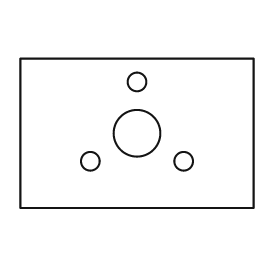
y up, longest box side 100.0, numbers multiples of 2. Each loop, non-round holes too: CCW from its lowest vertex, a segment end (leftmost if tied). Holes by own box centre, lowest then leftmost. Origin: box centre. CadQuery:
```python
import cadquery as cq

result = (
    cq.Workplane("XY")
    .moveTo(-50.0, -32.0)
    .lineTo(50.0, -32.0)
    .lineTo(50.0, 32.0)
    .lineTo(-50.0, 32.0)
    .close()
    .moveTo(-20.0, -12.0)
    .circle(4.0)
    .moveTo(20.0, -12.0)
    .circle(4.0)
    .moveTo(0.0, 0.0)
    .circle(10.0)
    .moveTo(0.0, 22.0)
    .circle(4.0)
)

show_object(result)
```